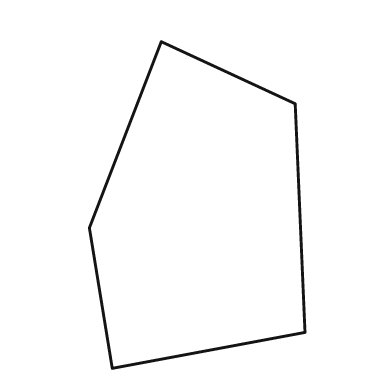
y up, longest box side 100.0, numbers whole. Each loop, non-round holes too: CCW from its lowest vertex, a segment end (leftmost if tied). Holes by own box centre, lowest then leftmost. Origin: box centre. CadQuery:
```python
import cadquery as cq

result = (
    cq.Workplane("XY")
    .moveTo(-26.0, -50.0)
    .lineTo(33.0, -39.0)
    .lineTo(30.0, 31.0)
    .lineTo(-11.0, 50.0)
    .lineTo(-33.0, -7.0)
    .close()
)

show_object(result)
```